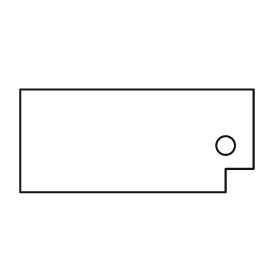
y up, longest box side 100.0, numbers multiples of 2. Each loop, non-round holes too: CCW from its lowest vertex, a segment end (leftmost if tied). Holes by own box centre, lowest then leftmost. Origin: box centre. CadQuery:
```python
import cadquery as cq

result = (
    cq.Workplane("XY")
    .moveTo(-50.0, -22.0)
    .lineTo(38.0, -22.0)
    .lineTo(38.0, -12.0)
    .lineTo(50.0, -12.0)
    .lineTo(50.0, 22.0)
    .lineTo(-50.0, 22.0)
    .close()
    .moveTo(38.0, -2.0)
    .circle(4.0)
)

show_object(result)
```